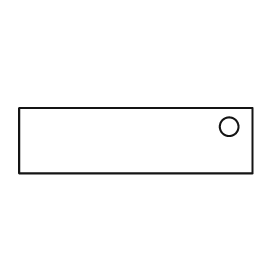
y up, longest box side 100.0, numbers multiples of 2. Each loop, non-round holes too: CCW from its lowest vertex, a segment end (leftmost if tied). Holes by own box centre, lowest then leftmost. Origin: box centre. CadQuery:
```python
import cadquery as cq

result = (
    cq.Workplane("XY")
    .moveTo(-50.0, -14.0)
    .lineTo(50.0, -14.0)
    .lineTo(50.0, 14.0)
    .lineTo(-50.0, 14.0)
    .close()
    .moveTo(40.0, 6.0)
    .circle(4.0)
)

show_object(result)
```